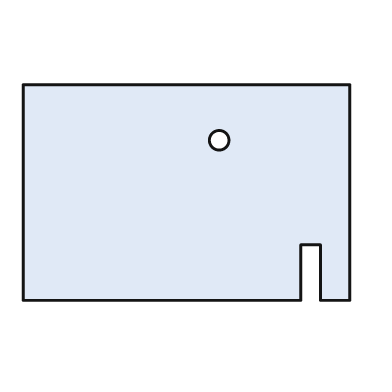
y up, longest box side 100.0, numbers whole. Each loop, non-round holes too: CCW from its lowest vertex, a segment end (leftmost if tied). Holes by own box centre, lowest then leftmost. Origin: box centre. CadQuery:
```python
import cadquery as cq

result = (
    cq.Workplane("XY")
    .moveTo(-50.0, -33.0)
    .lineTo(35.0, -33.0)
    .lineTo(35.0, -16.0)
    .lineTo(41.0, -16.0)
    .lineTo(41.0, -33.0)
    .lineTo(50.0, -33.0)
    .lineTo(50.0, 33.0)
    .lineTo(-50.0, 33.0)
    .close()
    .moveTo(10.0, 16.0)
    .circle(3.0)
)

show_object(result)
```